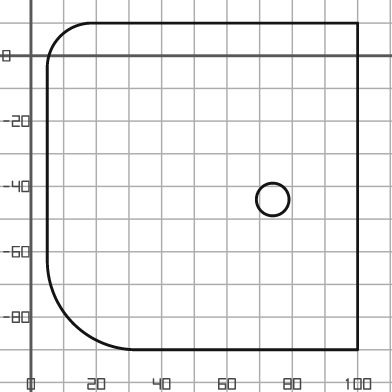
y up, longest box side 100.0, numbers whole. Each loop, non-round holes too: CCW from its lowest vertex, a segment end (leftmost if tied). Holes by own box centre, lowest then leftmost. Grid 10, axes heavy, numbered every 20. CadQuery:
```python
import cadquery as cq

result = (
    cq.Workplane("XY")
    .moveTo(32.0, -90.0)
    .lineTo(100.0, -90.0)
    .lineTo(100.0, 10.0)
    .lineTo(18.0, 10.0)
    .threePointArc((9.0, 6.0), (5.0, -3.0))
    .lineTo(5.0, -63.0)
    .threePointArc((13.0, -82.0), (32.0, -90.0))
    .close()
    .moveTo(74.0, -44.0)
    .circle(5.0)
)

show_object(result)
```